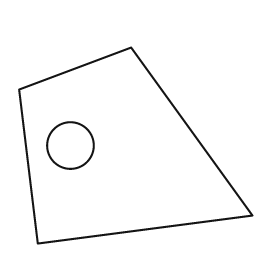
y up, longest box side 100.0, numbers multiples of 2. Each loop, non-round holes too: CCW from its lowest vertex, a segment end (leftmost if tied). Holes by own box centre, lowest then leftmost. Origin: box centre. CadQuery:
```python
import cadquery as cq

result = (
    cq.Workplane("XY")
    .moveTo(-42.0, -42.0)
    .lineTo(50.0, -30.0)
    .lineTo(-2.0, 42.0)
    .lineTo(-50.0, 24.0)
    .close()
    .moveTo(-28.0, 0.0)
    .circle(10.0)
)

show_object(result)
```